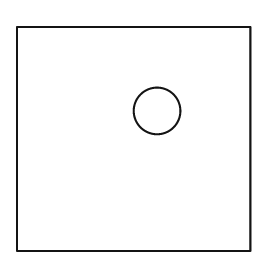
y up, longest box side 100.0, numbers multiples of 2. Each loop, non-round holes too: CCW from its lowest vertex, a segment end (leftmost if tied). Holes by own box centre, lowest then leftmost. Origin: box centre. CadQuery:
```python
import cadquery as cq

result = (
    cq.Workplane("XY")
    .moveTo(-50.0, -48.0)
    .lineTo(50.0, -48.0)
    .lineTo(50.0, 48.0)
    .lineTo(-50.0, 48.0)
    .close()
    .moveTo(10.0, 12.0)
    .circle(10.0)
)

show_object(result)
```